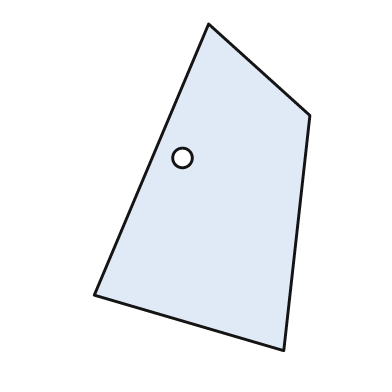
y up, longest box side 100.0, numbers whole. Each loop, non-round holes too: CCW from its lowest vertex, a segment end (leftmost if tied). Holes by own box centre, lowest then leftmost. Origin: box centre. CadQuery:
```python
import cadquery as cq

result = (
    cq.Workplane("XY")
    .moveTo(25.0, -50.0)
    .lineTo(33.0, 22.0)
    .lineTo(2.0, 50.0)
    .lineTo(-33.0, -33.0)
    .close()
    .moveTo(-6.0, 9.0)
    .circle(3.0)
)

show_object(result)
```